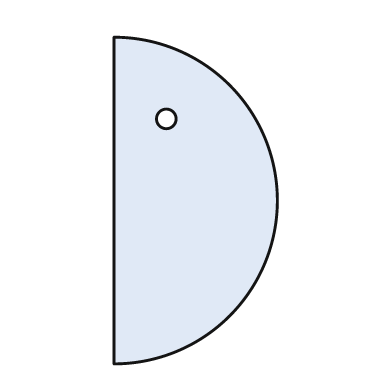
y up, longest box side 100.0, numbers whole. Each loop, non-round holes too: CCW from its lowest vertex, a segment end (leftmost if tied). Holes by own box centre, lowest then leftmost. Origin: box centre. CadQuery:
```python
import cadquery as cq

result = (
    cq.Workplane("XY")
    .moveTo(-25.0, -50.0)
    .threePointArc((25.0, 0.0), (-25.0, 50.0))
    .close()
    .moveTo(-9.0, 25.0)
    .circle(3.0)
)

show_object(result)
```